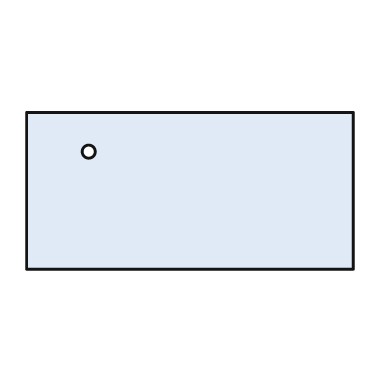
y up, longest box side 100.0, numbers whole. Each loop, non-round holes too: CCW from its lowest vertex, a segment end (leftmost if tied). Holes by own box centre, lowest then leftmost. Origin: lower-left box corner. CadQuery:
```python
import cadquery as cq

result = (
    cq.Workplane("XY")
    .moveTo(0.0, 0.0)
    .lineTo(100.0, 0.0)
    .lineTo(100.0, 48.0)
    .lineTo(0.0, 48.0)
    .close()
    .moveTo(19.0, 36.0)
    .circle(2.0)
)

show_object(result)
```